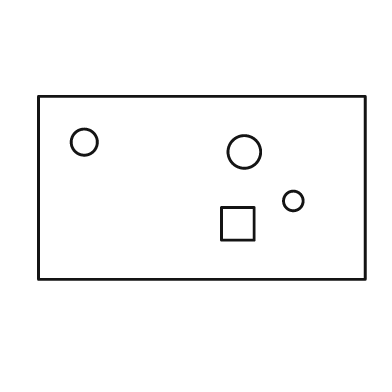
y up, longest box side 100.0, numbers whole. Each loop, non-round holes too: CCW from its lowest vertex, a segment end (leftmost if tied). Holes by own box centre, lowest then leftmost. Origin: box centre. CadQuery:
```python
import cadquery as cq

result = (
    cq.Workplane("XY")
    .moveTo(-50.0, -28.0)
    .lineTo(50.0, -28.0)
    .lineTo(50.0, 28.0)
    .lineTo(-50.0, 28.0)
    .close()
    .moveTo(6.0, -16.0)
    .lineTo(16.0, -16.0)
    .lineTo(16.0, -6.0)
    .lineTo(6.0, -6.0)
    .close()
    .moveTo(28.0, -4.0)
    .circle(3.0)
    .moveTo(13.0, 11.0)
    .circle(5.0)
    .moveTo(-36.0, 14.0)
    .circle(4.0)
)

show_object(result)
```